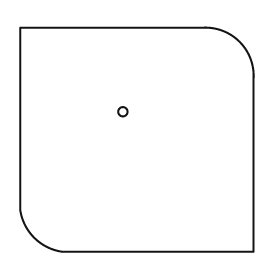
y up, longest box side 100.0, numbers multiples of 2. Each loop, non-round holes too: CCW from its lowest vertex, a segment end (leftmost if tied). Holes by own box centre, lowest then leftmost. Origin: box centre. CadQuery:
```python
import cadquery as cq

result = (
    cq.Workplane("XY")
    .moveTo(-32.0, -48.0)
    .lineTo(50.0, -48.0)
    .lineTo(50.0, 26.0)
    .threePointArc((44.0, 42.0), (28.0, 48.0))
    .lineTo(-50.0, 48.0)
    .lineTo(-50.0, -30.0)
    .threePointArc((-44.0, -42.0), (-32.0, -48.0))
    .close()
    .moveTo(-6.0, 12.0)
    .circle(2.0)
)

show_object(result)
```